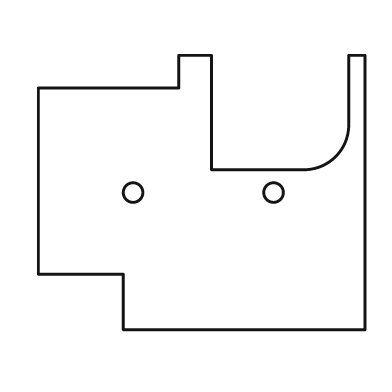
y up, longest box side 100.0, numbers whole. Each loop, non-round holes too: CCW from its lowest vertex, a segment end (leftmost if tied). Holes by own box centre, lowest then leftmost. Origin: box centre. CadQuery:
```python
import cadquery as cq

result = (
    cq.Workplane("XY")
    .moveTo(-24.0, -42.0)
    .lineTo(50.0, -42.0)
    .lineTo(50.0, 42.0)
    .lineTo(45.0, 42.0)
    .lineTo(45.0, 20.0)
    .threePointArc((41.0, 11.0), (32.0, 7.0))
    .lineTo(3.0, 7.0)
    .lineTo(3.0, 42.0)
    .lineTo(-7.0, 42.0)
    .lineTo(-7.0, 32.0)
    .lineTo(-50.0, 32.0)
    .lineTo(-50.0, -25.0)
    .lineTo(-24.0, -25.0)
    .close()
    .moveTo(-21.0, 0.0)
    .circle(3.0)
    .moveTo(22.0, 0.0)
    .circle(3.0)
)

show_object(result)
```